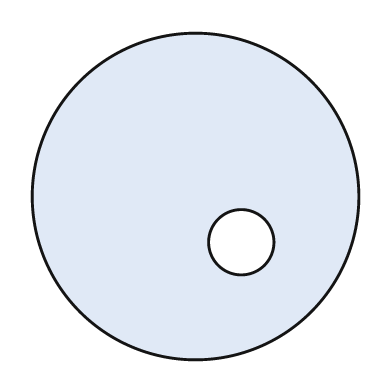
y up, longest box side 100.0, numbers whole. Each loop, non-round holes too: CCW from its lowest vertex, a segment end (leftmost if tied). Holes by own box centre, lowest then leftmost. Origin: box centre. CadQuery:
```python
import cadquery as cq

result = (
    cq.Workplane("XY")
    .moveTo(0.0, 0.0)
    .circle(50.0)
    .moveTo(14.0, -14.0)
    .circle(10.0)
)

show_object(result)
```